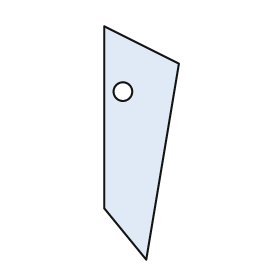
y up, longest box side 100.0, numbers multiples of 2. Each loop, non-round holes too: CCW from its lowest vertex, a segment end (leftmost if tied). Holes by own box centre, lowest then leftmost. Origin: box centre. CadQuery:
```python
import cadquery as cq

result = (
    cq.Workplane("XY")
    .moveTo(2.0, -50.0)
    .lineTo(16.0, 34.0)
    .lineTo(-16.0, 50.0)
    .lineTo(-16.0, -28.0)
    .close()
    .moveTo(-8.0, 22.0)
    .circle(4.0)
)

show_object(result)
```